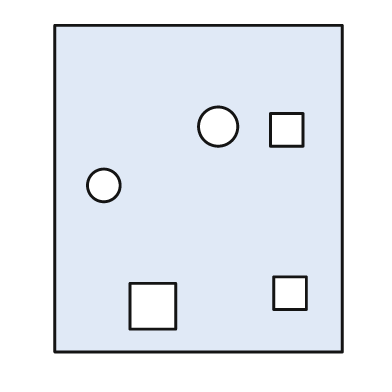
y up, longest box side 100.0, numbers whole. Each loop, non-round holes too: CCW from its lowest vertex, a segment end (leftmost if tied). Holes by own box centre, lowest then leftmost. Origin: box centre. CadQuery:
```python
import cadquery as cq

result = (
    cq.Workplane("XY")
    .moveTo(-44.0, -50.0)
    .lineTo(44.0, -50.0)
    .lineTo(44.0, 50.0)
    .lineTo(-44.0, 50.0)
    .close()
    .moveTo(-21.0, -43.0)
    .lineTo(-7.0, -43.0)
    .lineTo(-7.0, -29.0)
    .lineTo(-21.0, -29.0)
    .close()
    .moveTo(23.0, -37.0)
    .lineTo(33.0, -37.0)
    .lineTo(33.0, -27.0)
    .lineTo(23.0, -27.0)
    .close()
    .moveTo(-29.0, 1.0)
    .circle(5.0)
    .moveTo(22.0, 13.0)
    .lineTo(32.0, 13.0)
    .lineTo(32.0, 23.0)
    .lineTo(22.0, 23.0)
    .close()
    .moveTo(6.0, 19.0)
    .circle(6.0)
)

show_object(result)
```